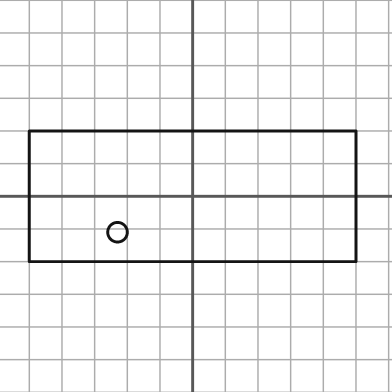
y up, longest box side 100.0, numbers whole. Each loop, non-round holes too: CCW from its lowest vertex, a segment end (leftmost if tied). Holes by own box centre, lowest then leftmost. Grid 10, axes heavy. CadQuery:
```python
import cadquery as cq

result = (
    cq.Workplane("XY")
    .moveTo(-50.0, -20.0)
    .lineTo(50.0, -20.0)
    .lineTo(50.0, 20.0)
    .lineTo(-50.0, 20.0)
    .close()
    .moveTo(-23.0, -11.0)
    .circle(3.0)
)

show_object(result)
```